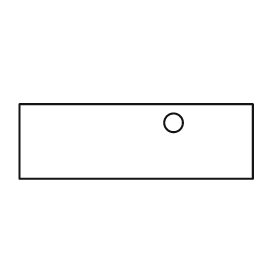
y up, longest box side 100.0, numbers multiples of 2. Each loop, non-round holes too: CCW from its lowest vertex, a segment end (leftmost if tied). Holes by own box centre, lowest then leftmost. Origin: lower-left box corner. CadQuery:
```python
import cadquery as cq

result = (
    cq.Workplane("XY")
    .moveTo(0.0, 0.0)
    .lineTo(100.0, 0.0)
    .lineTo(100.0, 32.0)
    .lineTo(0.0, 32.0)
    .close()
    .moveTo(66.0, 24.0)
    .circle(4.0)
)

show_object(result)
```